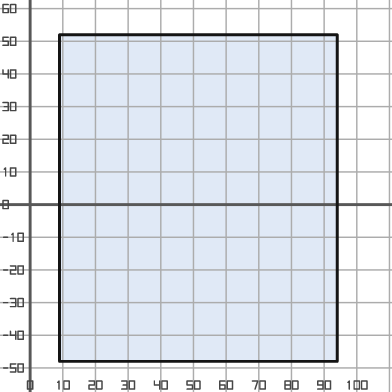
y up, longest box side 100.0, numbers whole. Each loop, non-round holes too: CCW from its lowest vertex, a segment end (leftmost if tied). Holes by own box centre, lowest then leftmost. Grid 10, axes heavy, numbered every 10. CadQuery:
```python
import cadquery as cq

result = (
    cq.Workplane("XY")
    .moveTo(9.0, -48.0)
    .lineTo(94.0, -48.0)
    .lineTo(94.0, 52.0)
    .lineTo(9.0, 52.0)
    .close()
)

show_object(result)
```